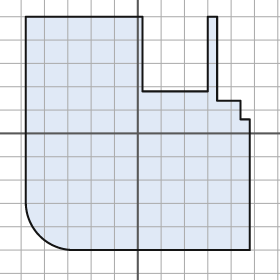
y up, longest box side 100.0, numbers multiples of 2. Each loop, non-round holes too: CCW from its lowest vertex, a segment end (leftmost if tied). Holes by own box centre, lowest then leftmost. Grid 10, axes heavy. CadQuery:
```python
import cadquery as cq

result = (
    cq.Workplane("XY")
    .moveTo(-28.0, -50.0)
    .lineTo(48.0, -50.0)
    .lineTo(48.0, 6.0)
    .lineTo(44.0, 6.0)
    .lineTo(44.0, 14.0)
    .lineTo(34.0, 14.0)
    .lineTo(34.0, 50.0)
    .lineTo(30.0, 50.0)
    .lineTo(30.0, 18.0)
    .lineTo(2.0, 18.0)
    .lineTo(2.0, 50.0)
    .lineTo(-48.0, 50.0)
    .lineTo(-48.0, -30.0)
    .threePointArc((-42.0, -44.0), (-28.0, -50.0))
    .close()
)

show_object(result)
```